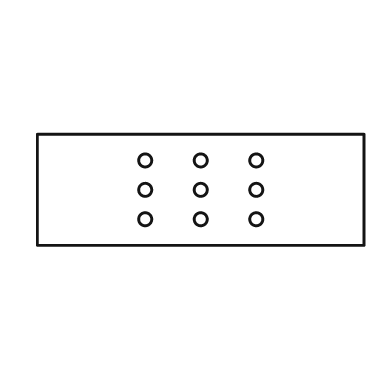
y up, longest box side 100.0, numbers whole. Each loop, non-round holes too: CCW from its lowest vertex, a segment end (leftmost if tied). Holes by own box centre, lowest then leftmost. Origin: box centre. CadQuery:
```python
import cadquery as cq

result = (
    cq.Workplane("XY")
    .moveTo(-50.0, -17.0)
    .lineTo(50.0, -17.0)
    .lineTo(50.0, 17.0)
    .lineTo(-50.0, 17.0)
    .close()
    .moveTo(-17.0, -9.0)
    .circle(2.0)
    .moveTo(0.0, -9.0)
    .circle(2.0)
    .moveTo(17.0, -9.0)
    .circle(2.0)
    .moveTo(-17.0, 0.0)
    .circle(2.0)
    .moveTo(0.0, 0.0)
    .circle(2.0)
    .moveTo(17.0, 0.0)
    .circle(2.0)
    .moveTo(-17.0, 9.0)
    .circle(2.0)
    .moveTo(0.0, 9.0)
    .circle(2.0)
    .moveTo(17.0, 9.0)
    .circle(2.0)
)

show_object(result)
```